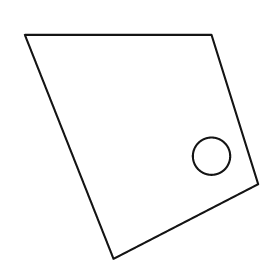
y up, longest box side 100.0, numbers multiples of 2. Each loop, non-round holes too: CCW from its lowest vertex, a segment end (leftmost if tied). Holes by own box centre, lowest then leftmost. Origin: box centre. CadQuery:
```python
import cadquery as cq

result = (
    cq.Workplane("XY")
    .moveTo(-12.0, -48.0)
    .lineTo(50.0, -16.0)
    .lineTo(30.0, 48.0)
    .lineTo(-50.0, 48.0)
    .close()
    .moveTo(30.0, -4.0)
    .circle(8.0)
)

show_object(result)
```